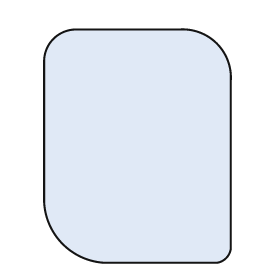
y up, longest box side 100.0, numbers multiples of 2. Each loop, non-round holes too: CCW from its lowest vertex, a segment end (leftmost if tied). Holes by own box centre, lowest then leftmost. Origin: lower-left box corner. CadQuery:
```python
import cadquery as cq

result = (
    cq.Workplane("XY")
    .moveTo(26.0, 0.0)
    .lineTo(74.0, 0.0)
    .threePointArc((78.0, 2.0), (80.0, 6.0))
    .lineTo(80.0, 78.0)
    .threePointArc((74.0, 94.0), (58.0, 100.0))
    .lineTo(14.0, 100.0)
    .threePointArc((4.0, 96.0), (0.0, 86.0))
    .lineTo(0.0, 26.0)
    .threePointArc((8.0, 8.0), (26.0, 0.0))
    .close()
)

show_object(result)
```